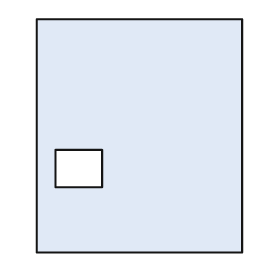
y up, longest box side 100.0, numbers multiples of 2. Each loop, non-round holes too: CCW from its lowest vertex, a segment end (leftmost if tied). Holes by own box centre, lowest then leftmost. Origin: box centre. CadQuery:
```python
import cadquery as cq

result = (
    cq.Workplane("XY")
    .moveTo(-44.0, -50.0)
    .lineTo(44.0, -50.0)
    .lineTo(44.0, 50.0)
    .lineTo(-44.0, 50.0)
    .close()
    .moveTo(-36.0, -22.0)
    .lineTo(-16.0, -22.0)
    .lineTo(-16.0, -6.0)
    .lineTo(-36.0, -6.0)
    .close()
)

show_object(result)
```